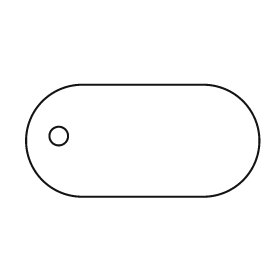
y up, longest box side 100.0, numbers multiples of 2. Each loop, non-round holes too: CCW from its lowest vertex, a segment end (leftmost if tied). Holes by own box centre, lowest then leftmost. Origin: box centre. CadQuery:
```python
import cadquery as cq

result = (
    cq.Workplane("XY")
    .moveTo(-26.0, -24.0)
    .lineTo(26.0, -24.0)
    .threePointArc((50.0, 0.0), (26.0, 24.0))
    .lineTo(-26.0, 24.0)
    .threePointArc((-50.0, 0.0), (-26.0, -24.0))
    .close()
    .moveTo(-36.0, 2.0)
    .circle(4.0)
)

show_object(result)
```